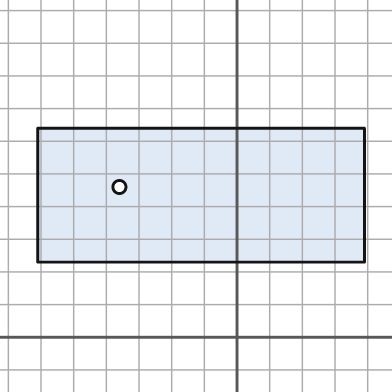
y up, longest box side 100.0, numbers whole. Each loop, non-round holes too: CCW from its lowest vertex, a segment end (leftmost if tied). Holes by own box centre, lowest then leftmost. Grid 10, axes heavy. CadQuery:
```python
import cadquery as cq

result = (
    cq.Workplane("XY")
    .moveTo(-61.0, 23.0)
    .lineTo(39.0, 23.0)
    .lineTo(39.0, 64.0)
    .lineTo(-61.0, 64.0)
    .close()
    .moveTo(-36.0, 46.0)
    .circle(2.0)
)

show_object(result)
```